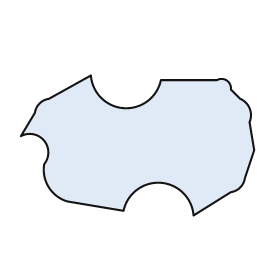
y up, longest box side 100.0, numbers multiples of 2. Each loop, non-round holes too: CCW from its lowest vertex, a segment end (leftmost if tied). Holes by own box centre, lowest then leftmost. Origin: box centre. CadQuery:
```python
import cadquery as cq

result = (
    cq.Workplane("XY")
    .moveTo(24.0, -30.0)
    .lineTo(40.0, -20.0)
    .threePointArc((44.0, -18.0), (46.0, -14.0))
    .lineTo(50.0, -2.0)
    .lineTo(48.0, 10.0)
    .threePointArc((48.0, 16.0), (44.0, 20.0))
    .lineTo(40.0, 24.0)
    .threePointArc((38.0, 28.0), (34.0, 28.0))
    .lineTo(10.0, 28.0)
    .threePointArc((-6.0, 16.0), (-20.0, 30.0))
    .lineTo(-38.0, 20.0)
    .threePointArc((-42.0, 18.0), (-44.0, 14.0))
    .lineTo(-50.0, 4.0)
    .threePointArc((-40.0, 2.0), (-40.0, -8.0))
    .threePointArc((-38.0, -18.0), (-30.0, -24.0))
    .lineTo(-6.0, -28.0)
    .threePointArc((10.0, -16.0), (24.0, -30.0))
    .close()
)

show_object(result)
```